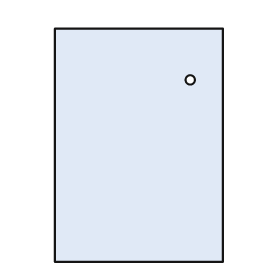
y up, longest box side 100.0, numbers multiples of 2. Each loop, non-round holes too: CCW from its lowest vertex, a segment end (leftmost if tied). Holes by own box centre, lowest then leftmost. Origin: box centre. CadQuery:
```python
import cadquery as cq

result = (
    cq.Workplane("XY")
    .moveTo(-36.0, -50.0)
    .lineTo(36.0, -50.0)
    .lineTo(36.0, 50.0)
    .lineTo(-36.0, 50.0)
    .close()
    .moveTo(22.0, 28.0)
    .circle(2.0)
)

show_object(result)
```